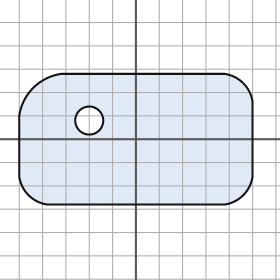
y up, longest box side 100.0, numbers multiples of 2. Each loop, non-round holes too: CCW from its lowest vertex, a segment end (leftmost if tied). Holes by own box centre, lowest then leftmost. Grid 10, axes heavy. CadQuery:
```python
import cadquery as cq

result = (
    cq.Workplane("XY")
    .moveTo(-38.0, -28.0)
    .lineTo(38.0, -28.0)
    .threePointArc((46.0, -24.0), (50.0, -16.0))
    .lineTo(50.0, 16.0)
    .threePointArc((46.0, 24.0), (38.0, 28.0))
    .lineTo(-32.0, 28.0)
    .threePointArc((-44.0, 22.0), (-50.0, 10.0))
    .lineTo(-50.0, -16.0)
    .threePointArc((-46.0, -24.0), (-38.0, -28.0))
    .close()
    .moveTo(-20.0, 8.0)
    .circle(6.0)
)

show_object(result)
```